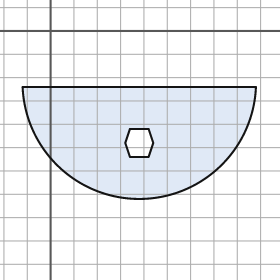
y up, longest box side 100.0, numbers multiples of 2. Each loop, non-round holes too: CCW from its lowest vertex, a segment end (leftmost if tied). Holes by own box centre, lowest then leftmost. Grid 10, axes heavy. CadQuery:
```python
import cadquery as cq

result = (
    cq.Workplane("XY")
    .moveTo(-12.0, -24.0)
    .threePointArc((38.0, -72.0), (88.0, -24.0))
    .close()
    .moveTo(34.0, -54.0)
    .lineTo(42.0, -54.0)
    .lineTo(44.0, -48.0)
    .lineTo(42.0, -42.0)
    .lineTo(34.0, -42.0)
    .lineTo(32.0, -48.0)
    .close()
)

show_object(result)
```